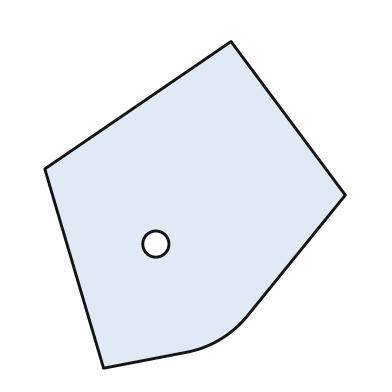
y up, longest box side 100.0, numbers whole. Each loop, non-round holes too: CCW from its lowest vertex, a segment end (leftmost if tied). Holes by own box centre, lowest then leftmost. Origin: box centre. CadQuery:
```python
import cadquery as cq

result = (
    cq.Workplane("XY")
    .moveTo(-28.0, -50.0)
    .lineTo(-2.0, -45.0)
    .threePointArc((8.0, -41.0), (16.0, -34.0))
    .lineTo(46.0, 3.0)
    .lineTo(11.0, 50.0)
    .lineTo(-46.0, 11.0)
    .close()
    .moveTo(-12.0, -12.0)
    .circle(4.0)
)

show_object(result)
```